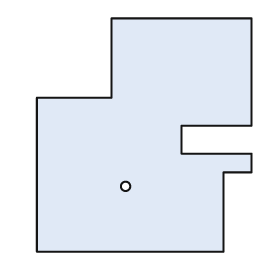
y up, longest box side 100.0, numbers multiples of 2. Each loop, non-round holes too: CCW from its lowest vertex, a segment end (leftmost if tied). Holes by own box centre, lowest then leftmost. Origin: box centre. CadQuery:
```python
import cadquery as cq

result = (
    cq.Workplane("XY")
    .moveTo(-46.0, -50.0)
    .lineTo(34.0, -50.0)
    .lineTo(34.0, -16.0)
    .lineTo(46.0, -16.0)
    .lineTo(46.0, -8.0)
    .lineTo(16.0, -8.0)
    .lineTo(16.0, 4.0)
    .lineTo(46.0, 4.0)
    .lineTo(46.0, 50.0)
    .lineTo(-14.0, 50.0)
    .lineTo(-14.0, 16.0)
    .lineTo(-46.0, 16.0)
    .close()
    .moveTo(-8.0, -22.0)
    .circle(2.0)
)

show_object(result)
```